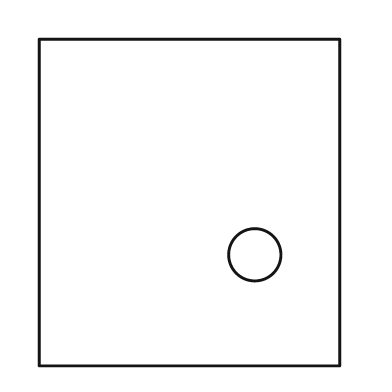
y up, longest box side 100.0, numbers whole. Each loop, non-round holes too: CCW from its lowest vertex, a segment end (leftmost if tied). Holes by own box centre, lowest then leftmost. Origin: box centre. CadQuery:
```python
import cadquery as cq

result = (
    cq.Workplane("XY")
    .moveTo(-46.0, -50.0)
    .lineTo(46.0, -50.0)
    .lineTo(46.0, 50.0)
    .lineTo(-46.0, 50.0)
    .close()
    .moveTo(20.0, -16.0)
    .circle(8.0)
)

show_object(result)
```